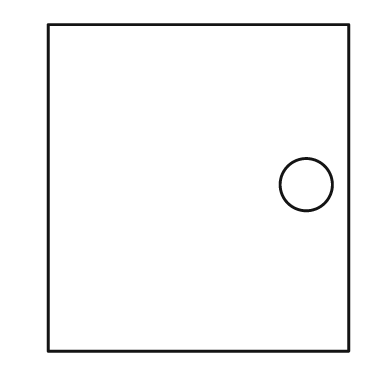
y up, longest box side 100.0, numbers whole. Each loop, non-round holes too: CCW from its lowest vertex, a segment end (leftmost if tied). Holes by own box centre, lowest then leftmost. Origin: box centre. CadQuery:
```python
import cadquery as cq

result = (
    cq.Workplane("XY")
    .moveTo(-46.0, -50.0)
    .lineTo(46.0, -50.0)
    .lineTo(46.0, 50.0)
    .lineTo(-46.0, 50.0)
    .close()
    .moveTo(33.0, 1.0)
    .circle(8.0)
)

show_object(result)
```